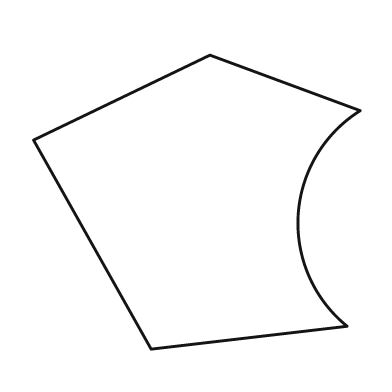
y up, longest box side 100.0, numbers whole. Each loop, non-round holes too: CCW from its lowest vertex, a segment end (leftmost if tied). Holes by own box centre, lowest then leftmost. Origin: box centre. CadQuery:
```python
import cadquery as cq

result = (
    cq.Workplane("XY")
    .moveTo(-14.0, -45.0)
    .lineTo(46.0, -38.0)
    .threePointArc((31.0, -4.0), (50.0, 28.0))
    .lineTo(4.0, 45.0)
    .lineTo(-50.0, 19.0)
    .close()
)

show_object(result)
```